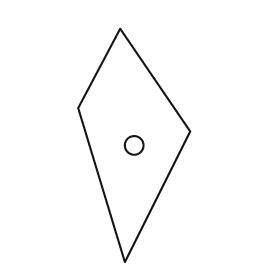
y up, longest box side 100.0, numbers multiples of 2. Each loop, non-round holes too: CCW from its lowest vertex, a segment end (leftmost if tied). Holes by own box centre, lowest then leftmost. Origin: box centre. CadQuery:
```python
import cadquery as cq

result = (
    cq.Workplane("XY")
    .moveTo(-4.0, -50.0)
    .lineTo(24.0, 6.0)
    .lineTo(-6.0, 50.0)
    .lineTo(-24.0, 16.0)
    .close()
    .moveTo(0.0, 0.0)
    .circle(4.0)
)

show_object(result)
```